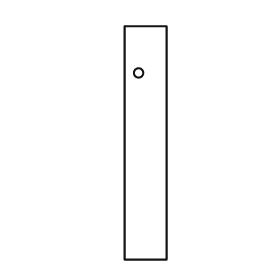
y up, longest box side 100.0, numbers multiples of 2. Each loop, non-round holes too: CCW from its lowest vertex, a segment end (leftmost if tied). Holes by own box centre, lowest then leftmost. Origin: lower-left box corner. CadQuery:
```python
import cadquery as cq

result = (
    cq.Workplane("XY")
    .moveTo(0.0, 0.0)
    .lineTo(18.0, 0.0)
    .lineTo(18.0, 100.0)
    .lineTo(0.0, 100.0)
    .close()
    .moveTo(6.0, 80.0)
    .circle(2.0)
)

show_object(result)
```